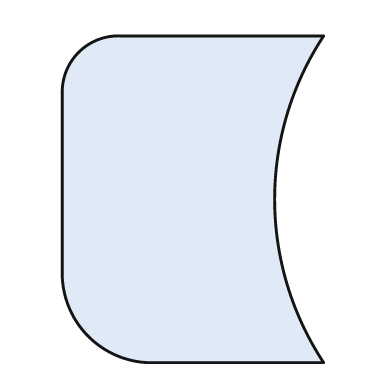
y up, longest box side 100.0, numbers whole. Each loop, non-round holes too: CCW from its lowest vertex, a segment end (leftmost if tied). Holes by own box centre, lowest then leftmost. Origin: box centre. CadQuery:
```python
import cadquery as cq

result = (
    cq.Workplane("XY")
    .moveTo(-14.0, -50.0)
    .lineTo(40.0, -50.0)
    .threePointArc((25.0, 0.0), (40.0, 50.0))
    .lineTo(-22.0, 50.0)
    .threePointArc((-35.0, 45.0), (-40.0, 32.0))
    .lineTo(-40.0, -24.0)
    .threePointArc((-32.0, -42.0), (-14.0, -50.0))
    .close()
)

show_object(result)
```